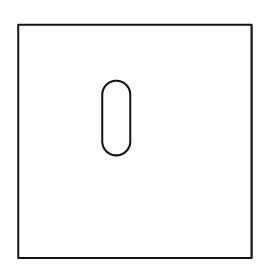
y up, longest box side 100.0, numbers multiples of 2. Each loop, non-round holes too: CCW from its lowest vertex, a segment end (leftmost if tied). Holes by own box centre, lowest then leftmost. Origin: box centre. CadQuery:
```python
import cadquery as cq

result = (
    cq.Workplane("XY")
    .moveTo(-50.0, -50.0)
    .lineTo(50.0, -50.0)
    .lineTo(50.0, 50.0)
    .lineTo(-50.0, 50.0)
    .close()
    .moveTo(-14.0, 0.0)
    .threePointArc((-8.0, -6.0), (-2.0, 0.0))
    .lineTo(-2.0, 20.0)
    .threePointArc((-8.0, 26.0), (-14.0, 20.0))
    .close()
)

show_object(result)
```